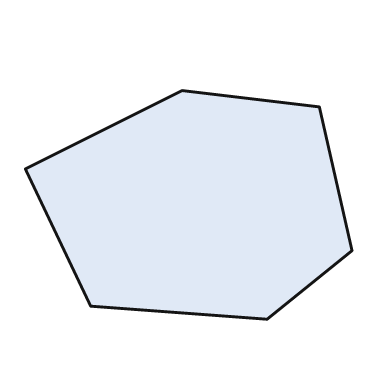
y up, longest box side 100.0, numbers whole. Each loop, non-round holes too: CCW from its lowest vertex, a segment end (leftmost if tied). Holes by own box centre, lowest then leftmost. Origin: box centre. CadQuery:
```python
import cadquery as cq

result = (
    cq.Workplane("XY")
    .moveTo(24.0, -35.0)
    .lineTo(50.0, -14.0)
    .lineTo(40.0, 30.0)
    .lineTo(-2.0, 35.0)
    .lineTo(-50.0, 11.0)
    .lineTo(-30.0, -31.0)
    .close()
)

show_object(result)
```